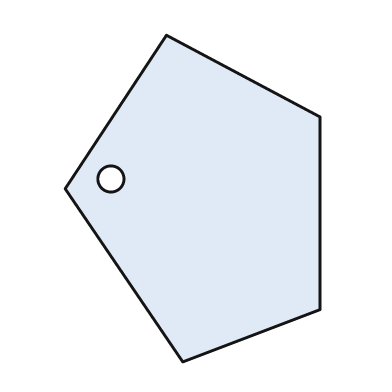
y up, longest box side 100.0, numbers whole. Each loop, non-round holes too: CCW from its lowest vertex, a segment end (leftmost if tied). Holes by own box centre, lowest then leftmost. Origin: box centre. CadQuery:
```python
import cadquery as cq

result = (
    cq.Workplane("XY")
    .moveTo(-3.0, -50.0)
    .lineTo(39.0, -34.0)
    .lineTo(39.0, 25.0)
    .lineTo(-8.0, 50.0)
    .lineTo(-39.0, 3.0)
    .close()
    .moveTo(-25.0, 6.0)
    .circle(4.0)
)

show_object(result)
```